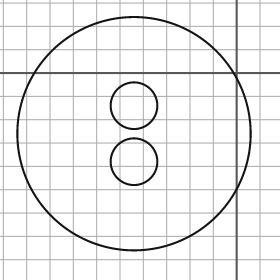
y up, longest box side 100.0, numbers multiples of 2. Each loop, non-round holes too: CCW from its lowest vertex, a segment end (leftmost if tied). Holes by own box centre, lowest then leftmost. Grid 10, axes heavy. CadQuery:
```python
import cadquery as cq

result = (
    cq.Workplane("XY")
    .moveTo(-44.0, -26.0)
    .circle(50.0)
    .moveTo(-44.0, -38.0)
    .circle(10.0)
    .moveTo(-44.0, -14.0)
    .circle(10.0)
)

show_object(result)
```